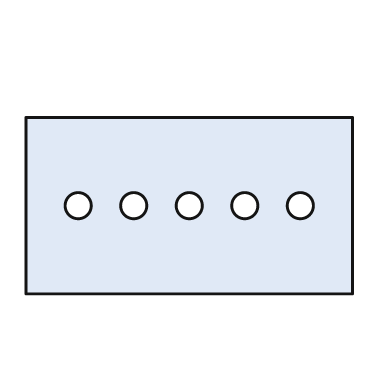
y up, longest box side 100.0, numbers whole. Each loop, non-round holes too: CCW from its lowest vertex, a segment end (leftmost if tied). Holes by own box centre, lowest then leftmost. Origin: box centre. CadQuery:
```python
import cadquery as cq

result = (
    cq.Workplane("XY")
    .moveTo(-50.0, -27.0)
    .lineTo(50.0, -27.0)
    .lineTo(50.0, 27.0)
    .lineTo(-50.0, 27.0)
    .close()
    .moveTo(-34.0, 0.0)
    .circle(4.0)
    .moveTo(-17.0, 0.0)
    .circle(4.0)
    .moveTo(0.0, 0.0)
    .circle(4.0)
    .moveTo(17.0, 0.0)
    .circle(4.0)
    .moveTo(34.0, 0.0)
    .circle(4.0)
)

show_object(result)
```